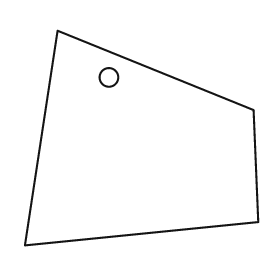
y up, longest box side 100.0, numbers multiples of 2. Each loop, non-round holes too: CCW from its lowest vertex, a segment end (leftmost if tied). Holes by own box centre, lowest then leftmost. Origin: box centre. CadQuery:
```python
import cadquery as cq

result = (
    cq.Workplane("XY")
    .moveTo(-50.0, -46.0)
    .lineTo(50.0, -36.0)
    .lineTo(48.0, 12.0)
    .lineTo(-36.0, 46.0)
    .close()
    .moveTo(-14.0, 26.0)
    .circle(4.0)
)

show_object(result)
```